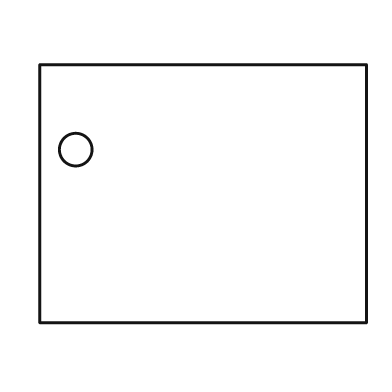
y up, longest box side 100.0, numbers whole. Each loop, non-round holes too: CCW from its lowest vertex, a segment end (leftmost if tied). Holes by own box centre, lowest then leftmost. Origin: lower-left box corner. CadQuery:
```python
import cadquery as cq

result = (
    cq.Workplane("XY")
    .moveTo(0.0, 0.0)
    .lineTo(100.0, 0.0)
    .lineTo(100.0, 79.0)
    .lineTo(0.0, 79.0)
    .close()
    .moveTo(11.0, 53.0)
    .circle(5.0)
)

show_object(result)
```